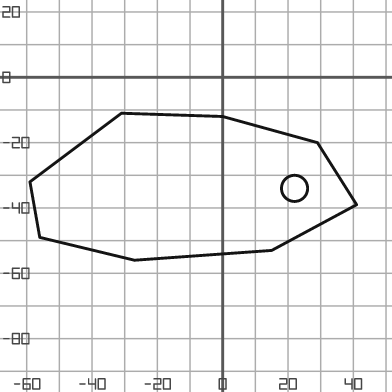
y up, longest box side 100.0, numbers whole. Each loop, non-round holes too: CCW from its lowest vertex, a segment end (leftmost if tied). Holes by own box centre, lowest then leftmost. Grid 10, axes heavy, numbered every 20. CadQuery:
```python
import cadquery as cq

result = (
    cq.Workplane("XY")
    .moveTo(-27.0, -56.0)
    .lineTo(15.0, -53.0)
    .lineTo(41.0, -39.0)
    .lineTo(29.0, -20.0)
    .lineTo(0.0, -12.0)
    .lineTo(-31.0, -11.0)
    .lineTo(-59.0, -32.0)
    .lineTo(-56.0, -49.0)
    .close()
    .moveTo(22.0, -34.0)
    .circle(4.0)
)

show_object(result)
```